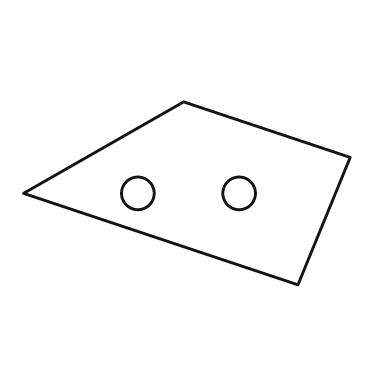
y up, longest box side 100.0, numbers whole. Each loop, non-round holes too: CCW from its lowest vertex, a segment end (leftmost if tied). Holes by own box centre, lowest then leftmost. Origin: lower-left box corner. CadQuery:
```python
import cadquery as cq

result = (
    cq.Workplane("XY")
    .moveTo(84.0, 0.0)
    .lineTo(100.0, 39.0)
    .lineTo(49.0, 56.0)
    .lineTo(0.0, 28.0)
    .close()
    .moveTo(35.0, 28.0)
    .circle(5.0)
    .moveTo(66.0, 28.0)
    .circle(5.0)
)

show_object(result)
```